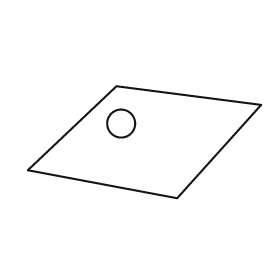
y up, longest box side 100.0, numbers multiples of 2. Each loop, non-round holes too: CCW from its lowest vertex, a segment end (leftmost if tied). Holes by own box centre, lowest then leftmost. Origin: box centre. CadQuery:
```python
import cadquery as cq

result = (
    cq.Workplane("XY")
    .moveTo(14.0, -24.0)
    .lineTo(50.0, 16.0)
    .lineTo(-12.0, 24.0)
    .lineTo(-50.0, -12.0)
    .close()
    .moveTo(-10.0, 8.0)
    .circle(6.0)
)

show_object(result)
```